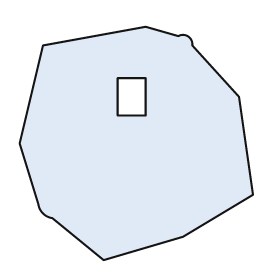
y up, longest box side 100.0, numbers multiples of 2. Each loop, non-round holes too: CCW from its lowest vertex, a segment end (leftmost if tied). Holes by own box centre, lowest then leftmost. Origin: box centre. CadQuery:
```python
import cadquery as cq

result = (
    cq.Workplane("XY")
    .moveTo(-14.0, -50.0)
    .lineTo(20.0, -40.0)
    .lineTo(50.0, -22.0)
    .lineTo(44.0, 20.0)
    .lineTo(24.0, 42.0)
    .threePointArc((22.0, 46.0), (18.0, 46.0))
    .lineTo(4.0, 50.0)
    .lineTo(-40.0, 42.0)
    .lineTo(-50.0, 0.0)
    .lineTo(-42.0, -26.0)
    .threePointArc((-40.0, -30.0), (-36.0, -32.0))
    .close()
    .moveTo(-8.0, 12.0)
    .lineTo(4.0, 12.0)
    .lineTo(4.0, 28.0)
    .lineTo(-8.0, 28.0)
    .close()
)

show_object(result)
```